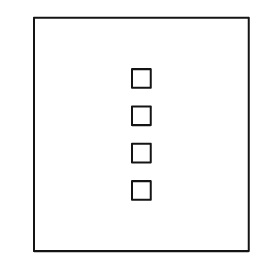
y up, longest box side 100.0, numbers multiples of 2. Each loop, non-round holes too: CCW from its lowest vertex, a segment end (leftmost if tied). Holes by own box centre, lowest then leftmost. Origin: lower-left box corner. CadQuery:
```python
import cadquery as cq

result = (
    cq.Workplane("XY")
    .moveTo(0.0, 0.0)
    .lineTo(92.0, 0.0)
    .lineTo(92.0, 100.0)
    .lineTo(0.0, 100.0)
    .close()
    .moveTo(42.0, 22.0)
    .lineTo(50.0, 22.0)
    .lineTo(50.0, 30.0)
    .lineTo(42.0, 30.0)
    .close()
    .moveTo(42.0, 38.0)
    .lineTo(50.0, 38.0)
    .lineTo(50.0, 46.0)
    .lineTo(42.0, 46.0)
    .close()
    .moveTo(42.0, 54.0)
    .lineTo(50.0, 54.0)
    .lineTo(50.0, 62.0)
    .lineTo(42.0, 62.0)
    .close()
    .moveTo(42.0, 70.0)
    .lineTo(50.0, 70.0)
    .lineTo(50.0, 78.0)
    .lineTo(42.0, 78.0)
    .close()
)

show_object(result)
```